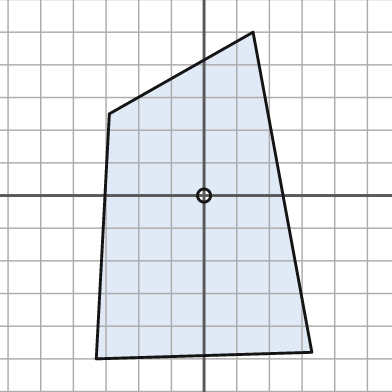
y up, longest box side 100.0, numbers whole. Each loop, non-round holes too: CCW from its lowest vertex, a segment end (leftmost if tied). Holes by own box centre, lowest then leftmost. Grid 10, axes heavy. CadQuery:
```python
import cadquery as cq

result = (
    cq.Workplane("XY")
    .moveTo(-33.0, -50.0)
    .lineTo(33.0, -48.0)
    .lineTo(15.0, 50.0)
    .lineTo(-29.0, 25.0)
    .close()
    .moveTo(0.0, 0.0)
    .circle(2.0)
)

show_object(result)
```